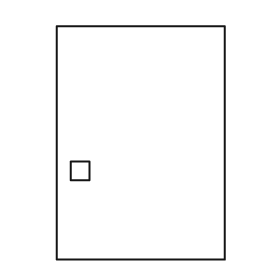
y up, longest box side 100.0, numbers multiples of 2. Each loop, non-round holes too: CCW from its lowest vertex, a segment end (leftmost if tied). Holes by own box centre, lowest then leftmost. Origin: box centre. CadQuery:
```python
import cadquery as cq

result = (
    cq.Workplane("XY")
    .moveTo(-36.0, -50.0)
    .lineTo(36.0, -50.0)
    .lineTo(36.0, 50.0)
    .lineTo(-36.0, 50.0)
    .close()
    .moveTo(-30.0, -16.0)
    .lineTo(-22.0, -16.0)
    .lineTo(-22.0, -8.0)
    .lineTo(-30.0, -8.0)
    .close()
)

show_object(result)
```